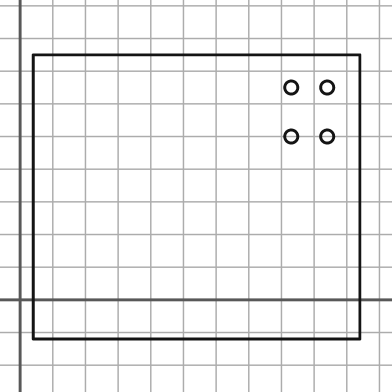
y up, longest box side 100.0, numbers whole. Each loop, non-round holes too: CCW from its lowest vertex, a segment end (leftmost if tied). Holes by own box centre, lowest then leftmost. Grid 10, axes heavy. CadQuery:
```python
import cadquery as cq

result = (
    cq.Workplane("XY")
    .moveTo(4.0, -12.0)
    .lineTo(104.0, -12.0)
    .lineTo(104.0, 75.0)
    .lineTo(4.0, 75.0)
    .close()
    .moveTo(83.0, 50.0)
    .circle(2.0)
    .moveTo(94.0, 50.0)
    .circle(2.0)
    .moveTo(83.0, 65.0)
    .circle(2.0)
    .moveTo(94.0, 65.0)
    .circle(2.0)
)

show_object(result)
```